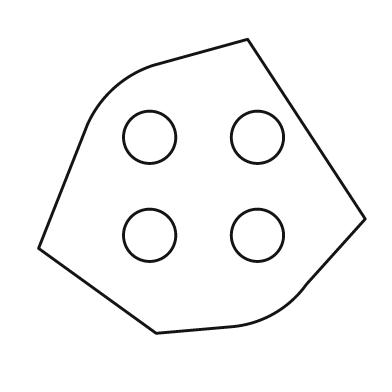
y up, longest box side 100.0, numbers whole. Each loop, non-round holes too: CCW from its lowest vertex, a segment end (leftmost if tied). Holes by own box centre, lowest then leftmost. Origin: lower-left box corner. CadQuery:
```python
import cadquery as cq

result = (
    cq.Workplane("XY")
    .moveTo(36.0, 0.0)
    .lineTo(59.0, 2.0)
    .threePointArc((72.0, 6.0), (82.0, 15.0))
    .lineTo(100.0, 35.0)
    .lineTo(64.0, 90.0)
    .lineTo(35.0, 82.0)
    .threePointArc((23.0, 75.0), (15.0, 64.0))
    .lineTo(0.0, 26.0)
    .close()
    .moveTo(34.0, 30.0)
    .circle(8.0)
    .moveTo(67.0, 30.0)
    .circle(8.0)
    .moveTo(34.0, 60.0)
    .circle(8.0)
    .moveTo(67.0, 60.0)
    .circle(8.0)
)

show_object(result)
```